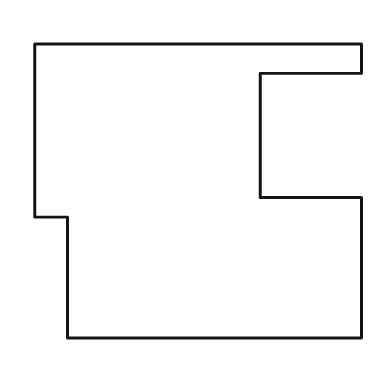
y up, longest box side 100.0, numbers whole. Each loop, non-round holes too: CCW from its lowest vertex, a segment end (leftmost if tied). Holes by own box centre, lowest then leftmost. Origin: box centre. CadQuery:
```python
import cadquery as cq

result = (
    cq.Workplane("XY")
    .moveTo(-40.0, -45.0)
    .lineTo(50.0, -45.0)
    .lineTo(50.0, -2.0)
    .lineTo(19.0, -2.0)
    .lineTo(19.0, 36.0)
    .lineTo(50.0, 36.0)
    .lineTo(50.0, 45.0)
    .lineTo(-50.0, 45.0)
    .lineTo(-50.0, -8.0)
    .lineTo(-40.0, -8.0)
    .close()
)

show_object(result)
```